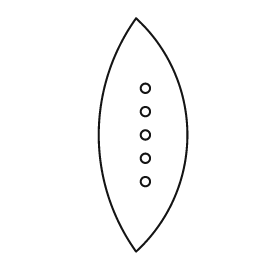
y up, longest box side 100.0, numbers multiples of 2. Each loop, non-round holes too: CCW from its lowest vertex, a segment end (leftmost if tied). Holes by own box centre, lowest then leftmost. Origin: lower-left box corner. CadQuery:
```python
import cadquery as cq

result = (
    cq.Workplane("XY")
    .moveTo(16.0, 0.0)
    .threePointArc((38.0, 50.0), (16.0, 100.0))
    .threePointArc((0.0, 50.0), (16.0, 0.0))
    .close()
    .moveTo(20.0, 30.0)
    .circle(2.0)
    .moveTo(20.0, 40.0)
    .circle(2.0)
    .moveTo(20.0, 50.0)
    .circle(2.0)
    .moveTo(20.0, 60.0)
    .circle(2.0)
    .moveTo(20.0, 70.0)
    .circle(2.0)
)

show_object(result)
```